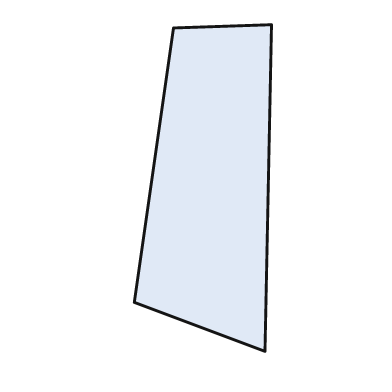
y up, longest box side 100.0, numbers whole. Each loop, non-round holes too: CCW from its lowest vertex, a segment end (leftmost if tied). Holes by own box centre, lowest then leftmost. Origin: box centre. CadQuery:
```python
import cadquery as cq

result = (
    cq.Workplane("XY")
    .moveTo(19.0, -50.0)
    .lineTo(21.0, 50.0)
    .lineTo(-9.0, 49.0)
    .lineTo(-21.0, -35.0)
    .close()
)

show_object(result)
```